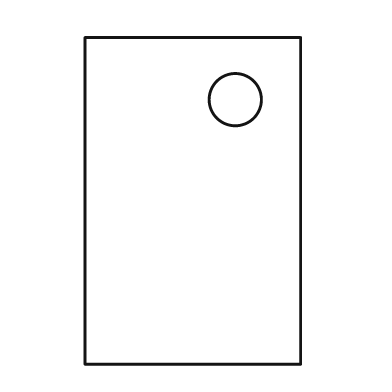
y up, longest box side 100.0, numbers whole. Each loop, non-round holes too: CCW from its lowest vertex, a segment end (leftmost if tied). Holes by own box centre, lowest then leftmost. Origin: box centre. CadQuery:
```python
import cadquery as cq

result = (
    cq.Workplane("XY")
    .moveTo(-33.0, -50.0)
    .lineTo(33.0, -50.0)
    .lineTo(33.0, 50.0)
    .lineTo(-33.0, 50.0)
    .close()
    .moveTo(13.0, 31.0)
    .circle(8.0)
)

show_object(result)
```